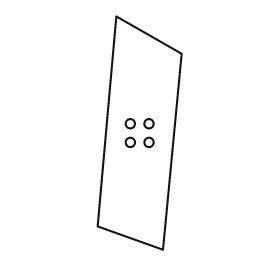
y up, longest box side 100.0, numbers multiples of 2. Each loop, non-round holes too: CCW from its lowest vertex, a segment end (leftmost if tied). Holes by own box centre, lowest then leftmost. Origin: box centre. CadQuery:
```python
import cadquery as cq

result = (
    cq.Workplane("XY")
    .moveTo(10.0, -50.0)
    .lineTo(18.0, 34.0)
    .lineTo(-10.0, 50.0)
    .lineTo(-18.0, -40.0)
    .close()
    .moveTo(-4.0, -4.0)
    .circle(2.0)
    .moveTo(4.0, -4.0)
    .circle(2.0)
    .moveTo(-4.0, 4.0)
    .circle(2.0)
    .moveTo(4.0, 4.0)
    .circle(2.0)
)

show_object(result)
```